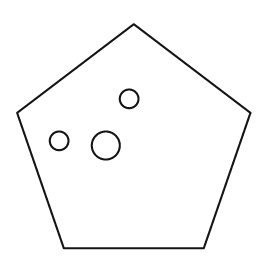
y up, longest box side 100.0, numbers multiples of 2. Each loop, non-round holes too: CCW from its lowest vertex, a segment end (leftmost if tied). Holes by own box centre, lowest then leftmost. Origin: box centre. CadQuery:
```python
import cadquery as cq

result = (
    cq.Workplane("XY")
    .moveTo(-30.0, -48.0)
    .lineTo(30.0, -48.0)
    .lineTo(50.0, 10.0)
    .lineTo(0.0, 48.0)
    .lineTo(-50.0, 10.0)
    .close()
    .moveTo(-12.0, -4.0)
    .circle(6.0)
    .moveTo(-32.0, -2.0)
    .circle(4.0)
    .moveTo(-2.0, 16.0)
    .circle(4.0)
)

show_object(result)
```